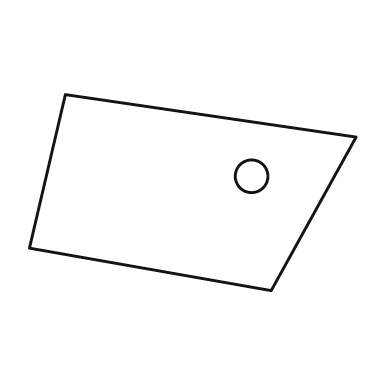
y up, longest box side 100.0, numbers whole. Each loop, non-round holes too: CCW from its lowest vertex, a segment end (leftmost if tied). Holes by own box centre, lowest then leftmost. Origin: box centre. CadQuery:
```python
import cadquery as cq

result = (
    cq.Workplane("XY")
    .moveTo(24.0, -30.0)
    .lineTo(50.0, 17.0)
    .lineTo(-39.0, 30.0)
    .lineTo(-50.0, -17.0)
    .close()
    .moveTo(18.0, 5.0)
    .circle(5.0)
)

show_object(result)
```